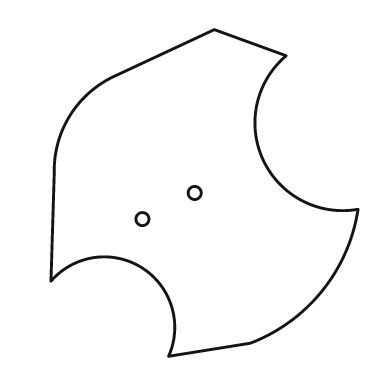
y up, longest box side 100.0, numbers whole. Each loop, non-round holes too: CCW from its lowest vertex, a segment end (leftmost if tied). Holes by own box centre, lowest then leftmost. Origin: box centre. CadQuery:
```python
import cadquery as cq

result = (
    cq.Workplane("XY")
    .moveTo(-11.0, -50.0)
    .lineTo(14.0, -46.0)
    .threePointArc((36.0, -30.0), (47.0, -5.0))
    .threePointArc((18.0, 10.0), (25.0, 42.0))
    .lineTo(3.0, 50.0)
    .lineTo(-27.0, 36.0)
    .threePointArc((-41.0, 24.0), (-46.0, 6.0))
    .lineTo(-47.0, -27.0)
    .threePointArc((-19.0, -23.0), (-11.0, -50.0))
    .close()
    .moveTo(-19.0, -8.0)
    .circle(2.0)
    .moveTo(-3.0, 0.0)
    .circle(2.0)
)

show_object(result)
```